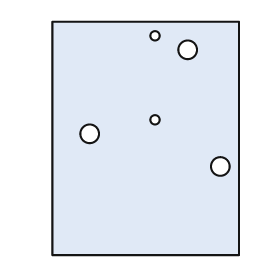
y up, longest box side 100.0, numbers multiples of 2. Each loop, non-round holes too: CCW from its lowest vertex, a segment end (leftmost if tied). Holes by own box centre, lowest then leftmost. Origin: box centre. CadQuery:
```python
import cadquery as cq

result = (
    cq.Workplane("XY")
    .moveTo(-40.0, -50.0)
    .lineTo(40.0, -50.0)
    .lineTo(40.0, 50.0)
    .lineTo(-40.0, 50.0)
    .close()
    .moveTo(32.0, -12.0)
    .circle(4.0)
    .moveTo(-24.0, 2.0)
    .circle(4.0)
    .moveTo(4.0, 8.0)
    .circle(2.0)
    .moveTo(18.0, 38.0)
    .circle(4.0)
    .moveTo(4.0, 44.0)
    .circle(2.0)
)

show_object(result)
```